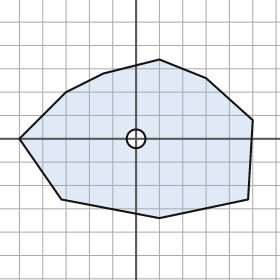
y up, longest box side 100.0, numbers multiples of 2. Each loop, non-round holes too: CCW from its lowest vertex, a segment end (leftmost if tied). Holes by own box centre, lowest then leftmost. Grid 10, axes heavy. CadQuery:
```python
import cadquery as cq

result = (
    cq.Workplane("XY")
    .moveTo(10.0, -34.0)
    .lineTo(48.0, -26.0)
    .lineTo(50.0, 8.0)
    .lineTo(30.0, 26.0)
    .lineTo(10.0, 34.0)
    .lineTo(-14.0, 28.0)
    .lineTo(-30.0, 20.0)
    .lineTo(-50.0, 0.0)
    .lineTo(-32.0, -26.0)
    .close()
    .moveTo(0.0, 0.0)
    .circle(4.0)
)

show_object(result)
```